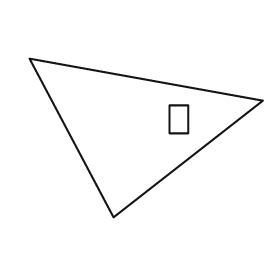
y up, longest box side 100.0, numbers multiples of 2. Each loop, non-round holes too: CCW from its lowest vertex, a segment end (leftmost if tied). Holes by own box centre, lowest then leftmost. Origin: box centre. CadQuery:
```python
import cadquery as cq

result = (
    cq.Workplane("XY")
    .moveTo(-14.0, -34.0)
    .lineTo(50.0, 16.0)
    .lineTo(-50.0, 34.0)
    .close()
    .moveTo(10.0, 2.0)
    .lineTo(18.0, 2.0)
    .lineTo(18.0, 14.0)
    .lineTo(10.0, 14.0)
    .close()
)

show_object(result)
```